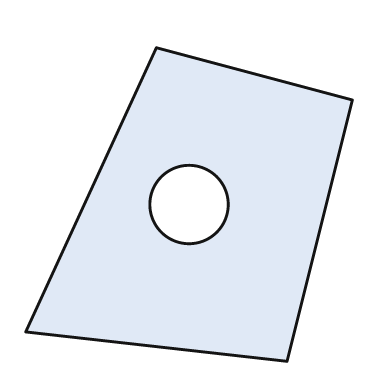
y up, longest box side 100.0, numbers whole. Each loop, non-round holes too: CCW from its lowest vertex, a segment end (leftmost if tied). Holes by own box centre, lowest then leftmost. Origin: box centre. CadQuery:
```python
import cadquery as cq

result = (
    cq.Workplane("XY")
    .moveTo(30.0, -48.0)
    .lineTo(50.0, 32.0)
    .lineTo(-10.0, 48.0)
    .lineTo(-50.0, -39.0)
    .close()
    .moveTo(0.0, 0.0)
    .circle(12.0)
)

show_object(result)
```